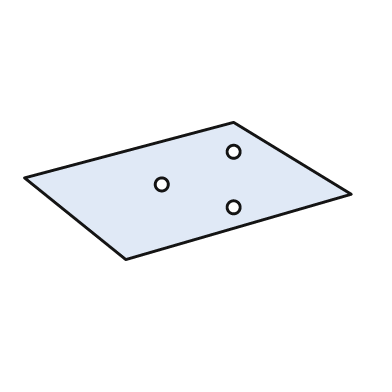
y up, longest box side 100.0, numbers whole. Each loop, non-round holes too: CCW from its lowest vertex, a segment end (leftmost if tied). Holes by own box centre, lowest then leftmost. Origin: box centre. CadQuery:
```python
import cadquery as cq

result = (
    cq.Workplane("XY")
    .moveTo(-19.0, -21.0)
    .lineTo(50.0, -1.0)
    .lineTo(14.0, 21.0)
    .lineTo(-50.0, 4.0)
    .close()
    .moveTo(14.0, -5.0)
    .circle(2.0)
    .moveTo(-8.0, 2.0)
    .circle(2.0)
    .moveTo(14.0, 12.0)
    .circle(2.0)
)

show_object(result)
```